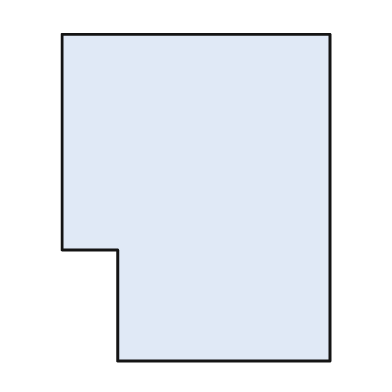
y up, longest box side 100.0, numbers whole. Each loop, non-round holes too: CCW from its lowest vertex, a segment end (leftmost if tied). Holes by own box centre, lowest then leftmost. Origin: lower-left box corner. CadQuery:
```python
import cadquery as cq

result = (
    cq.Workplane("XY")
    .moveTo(17.0, 0.0)
    .lineTo(82.0, 0.0)
    .lineTo(82.0, 100.0)
    .lineTo(0.0, 100.0)
    .lineTo(0.0, 34.0)
    .lineTo(17.0, 34.0)
    .close()
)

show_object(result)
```